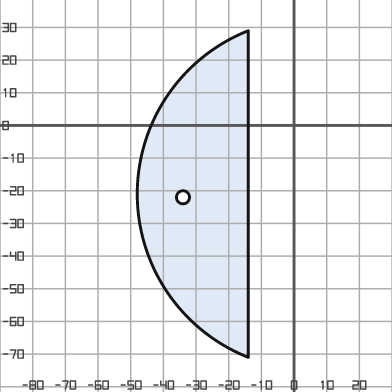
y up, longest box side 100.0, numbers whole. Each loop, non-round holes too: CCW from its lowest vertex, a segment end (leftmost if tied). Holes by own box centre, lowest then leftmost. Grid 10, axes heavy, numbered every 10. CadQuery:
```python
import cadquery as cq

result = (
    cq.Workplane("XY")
    .moveTo(-14.0, -71.0)
    .lineTo(-14.0, 29.0)
    .threePointArc((-48.0, -21.0), (-14.0, -71.0))
    .close()
    .moveTo(-34.0, -22.0)
    .circle(2.0)
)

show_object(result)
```